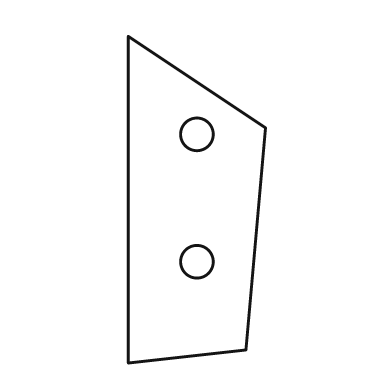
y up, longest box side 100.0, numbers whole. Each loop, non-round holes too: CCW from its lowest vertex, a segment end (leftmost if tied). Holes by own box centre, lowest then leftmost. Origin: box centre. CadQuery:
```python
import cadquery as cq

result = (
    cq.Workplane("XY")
    .moveTo(-21.0, -50.0)
    .lineTo(15.0, -46.0)
    .lineTo(21.0, 22.0)
    .lineTo(-21.0, 50.0)
    .close()
    .moveTo(0.0, -19.0)
    .circle(5.0)
    .moveTo(0.0, 20.0)
    .circle(5.0)
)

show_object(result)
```